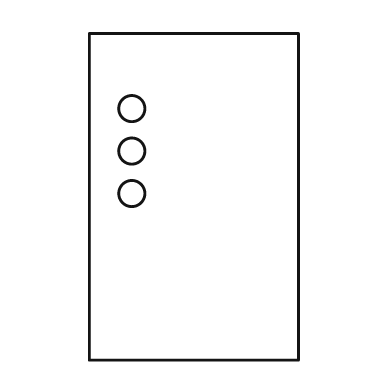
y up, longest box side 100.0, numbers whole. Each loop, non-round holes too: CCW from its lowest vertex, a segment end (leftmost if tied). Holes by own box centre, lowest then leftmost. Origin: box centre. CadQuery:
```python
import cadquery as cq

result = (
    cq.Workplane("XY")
    .moveTo(-32.0, -50.0)
    .lineTo(32.0, -50.0)
    .lineTo(32.0, 50.0)
    .lineTo(-32.0, 50.0)
    .close()
    .moveTo(-19.0, 1.0)
    .circle(4.0)
    .moveTo(-19.0, 14.0)
    .circle(4.0)
    .moveTo(-19.0, 27.0)
    .circle(4.0)
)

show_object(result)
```